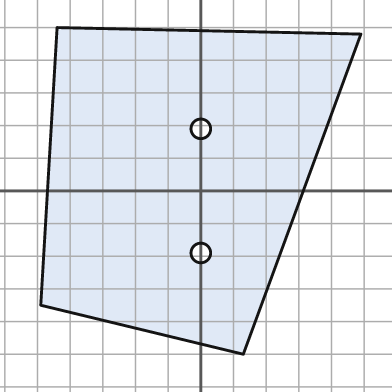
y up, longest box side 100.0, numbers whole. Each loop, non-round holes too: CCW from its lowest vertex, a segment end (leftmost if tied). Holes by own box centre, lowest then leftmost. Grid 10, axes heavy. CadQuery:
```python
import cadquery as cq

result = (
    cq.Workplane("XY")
    .moveTo(13.0, -50.0)
    .lineTo(49.0, 48.0)
    .lineTo(-44.0, 50.0)
    .lineTo(-49.0, -35.0)
    .close()
    .moveTo(0.0, -19.0)
    .circle(3.0)
    .moveTo(0.0, 19.0)
    .circle(3.0)
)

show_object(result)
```